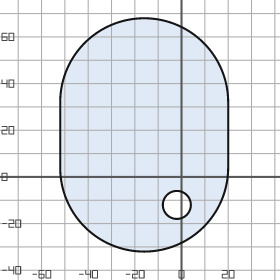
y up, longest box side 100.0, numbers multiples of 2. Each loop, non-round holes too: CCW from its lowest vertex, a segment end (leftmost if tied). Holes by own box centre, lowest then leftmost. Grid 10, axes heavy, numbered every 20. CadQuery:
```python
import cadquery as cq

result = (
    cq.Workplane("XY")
    .moveTo(-52.0, 4.0)
    .threePointArc((-16.0, -32.0), (20.0, 4.0))
    .lineTo(20.0, 32.0)
    .threePointArc((-16.0, 68.0), (-52.0, 32.0))
    .close()
    .moveTo(-2.0, -12.0)
    .circle(6.0)
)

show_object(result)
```